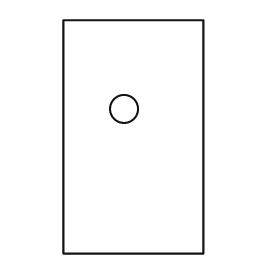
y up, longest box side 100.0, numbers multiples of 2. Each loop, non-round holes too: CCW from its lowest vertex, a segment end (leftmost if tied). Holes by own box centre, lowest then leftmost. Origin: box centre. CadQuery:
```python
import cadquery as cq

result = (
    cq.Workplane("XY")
    .moveTo(-30.0, -50.0)
    .lineTo(30.0, -50.0)
    .lineTo(30.0, 50.0)
    .lineTo(-30.0, 50.0)
    .close()
    .moveTo(-4.0, 12.0)
    .circle(6.0)
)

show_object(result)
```